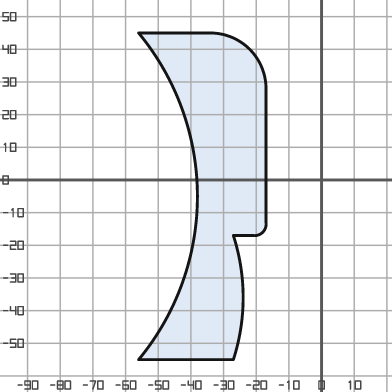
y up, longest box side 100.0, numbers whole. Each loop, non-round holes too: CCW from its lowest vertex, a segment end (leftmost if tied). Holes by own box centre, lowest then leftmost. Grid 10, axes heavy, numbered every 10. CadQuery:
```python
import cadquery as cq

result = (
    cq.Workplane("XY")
    .moveTo(-56.0, -55.0)
    .lineTo(-27.0, -55.0)
    .threePointArc((-24.0, -36.0), (-27.0, -17.0))
    .lineTo(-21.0, -17.0)
    .threePointArc((-18.0, -16.0), (-17.0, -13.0))
    .lineTo(-17.0, 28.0)
    .threePointArc((-22.0, 40.0), (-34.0, 45.0))
    .lineTo(-56.0, 45.0)
    .threePointArc((-38.0, -5.0), (-56.0, -55.0))
    .close()
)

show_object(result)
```